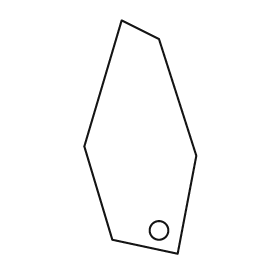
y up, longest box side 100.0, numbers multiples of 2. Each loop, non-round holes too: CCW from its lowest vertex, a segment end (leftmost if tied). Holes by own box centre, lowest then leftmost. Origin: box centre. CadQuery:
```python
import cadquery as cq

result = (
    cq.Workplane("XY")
    .moveTo(16.0, -50.0)
    .lineTo(24.0, -8.0)
    .lineTo(8.0, 42.0)
    .lineTo(-8.0, 50.0)
    .lineTo(-24.0, -4.0)
    .lineTo(-12.0, -44.0)
    .close()
    .moveTo(8.0, -40.0)
    .circle(4.0)
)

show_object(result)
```